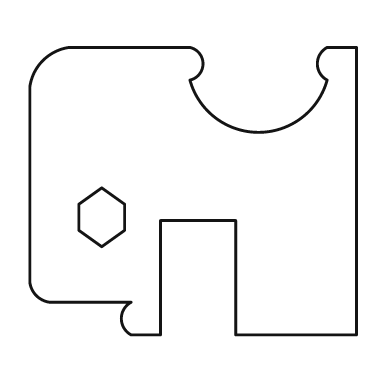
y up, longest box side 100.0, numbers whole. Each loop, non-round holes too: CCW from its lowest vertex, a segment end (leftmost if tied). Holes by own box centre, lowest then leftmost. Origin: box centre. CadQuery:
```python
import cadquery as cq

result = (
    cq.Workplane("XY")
    .moveTo(-19.0, -44.0)
    .lineTo(-10.0, -44.0)
    .lineTo(-10.0, -9.0)
    .lineTo(13.0, -9.0)
    .lineTo(13.0, -44.0)
    .lineTo(50.0, -44.0)
    .lineTo(50.0, 44.0)
    .lineTo(41.0, 44.0)
    .threePointArc((38.0, 39.0), (41.0, 34.0))
    .threePointArc((20.0, 18.0), (-1.0, 34.0))
    .threePointArc((3.0, 39.0), (-1.0, 44.0))
    .lineTo(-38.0, 44.0)
    .threePointArc((-46.0, 40.0), (-50.0, 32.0))
    .lineTo(-50.0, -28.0)
    .threePointArc((-48.0, -32.0), (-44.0, -34.0))
    .lineTo(-19.0, -34.0)
    .threePointArc((-22.0, -39.0), (-19.0, -44.0))
    .close()
    .moveTo(-28.0, -17.0)
    .lineTo(-21.0, -12.0)
    .lineTo(-21.0, -4.0)
    .lineTo(-28.0, 1.0)
    .lineTo(-35.0, -4.0)
    .lineTo(-35.0, -12.0)
    .close()
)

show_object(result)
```